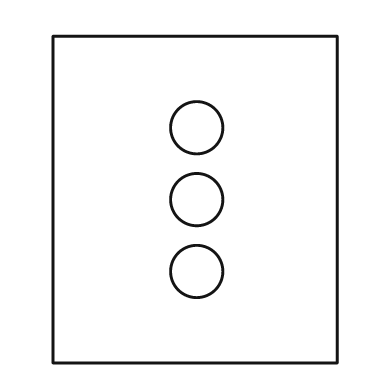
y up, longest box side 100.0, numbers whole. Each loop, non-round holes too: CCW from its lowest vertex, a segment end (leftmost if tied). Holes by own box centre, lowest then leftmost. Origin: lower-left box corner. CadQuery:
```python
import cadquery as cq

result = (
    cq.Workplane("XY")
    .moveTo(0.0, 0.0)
    .lineTo(87.0, 0.0)
    .lineTo(87.0, 100.0)
    .lineTo(0.0, 100.0)
    .close()
    .moveTo(44.0, 28.0)
    .circle(8.0)
    .moveTo(44.0, 50.0)
    .circle(8.0)
    .moveTo(44.0, 72.0)
    .circle(8.0)
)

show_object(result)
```